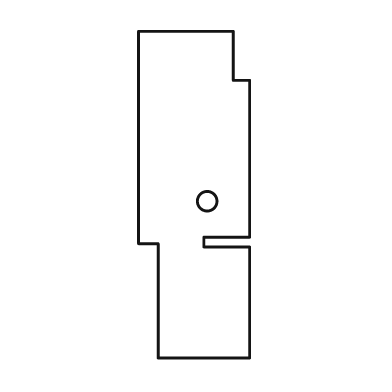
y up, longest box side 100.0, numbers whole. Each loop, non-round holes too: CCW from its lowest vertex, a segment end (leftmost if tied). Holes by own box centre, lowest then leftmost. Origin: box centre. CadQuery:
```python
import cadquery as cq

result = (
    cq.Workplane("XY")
    .moveTo(-11.0, -50.0)
    .lineTo(17.0, -50.0)
    .lineTo(17.0, -16.0)
    .lineTo(3.0, -16.0)
    .lineTo(3.0, -13.0)
    .lineTo(17.0, -13.0)
    .lineTo(17.0, 35.0)
    .lineTo(12.0, 35.0)
    .lineTo(12.0, 50.0)
    .lineTo(-17.0, 50.0)
    .lineTo(-17.0, -15.0)
    .lineTo(-11.0, -15.0)
    .close()
    .moveTo(4.0, -2.0)
    .circle(3.0)
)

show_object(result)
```